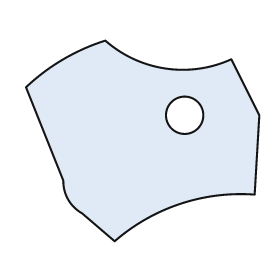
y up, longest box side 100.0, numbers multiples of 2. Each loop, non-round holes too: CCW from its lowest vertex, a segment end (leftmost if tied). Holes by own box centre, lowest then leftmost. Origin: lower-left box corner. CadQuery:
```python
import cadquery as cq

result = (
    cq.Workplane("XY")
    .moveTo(38.0, 0.0)
    .threePointArc((66.0, 16.0), (98.0, 20.0))
    .lineTo(100.0, 54.0)
    .lineTo(88.0, 78.0)
    .threePointArc((60.0, 74.0), (34.0, 86.0))
    .threePointArc((16.0, 78.0), (0.0, 66.0))
    .lineTo(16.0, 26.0)
    .threePointArc((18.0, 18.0), (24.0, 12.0))
    .close()
    .moveTo(68.0, 54.0)
    .circle(8.0)
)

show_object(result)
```